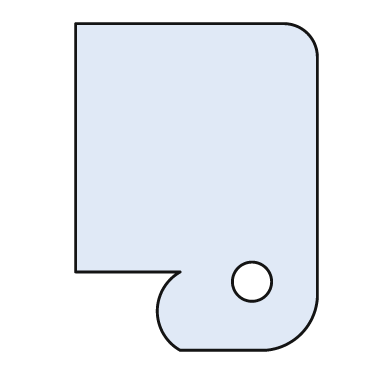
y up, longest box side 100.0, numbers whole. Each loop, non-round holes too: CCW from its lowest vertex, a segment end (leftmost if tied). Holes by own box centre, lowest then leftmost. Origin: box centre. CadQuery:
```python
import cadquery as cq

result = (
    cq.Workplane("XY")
    .moveTo(-5.0, -50.0)
    .lineTo(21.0, -50.0)
    .threePointArc((32.0, -45.0), (37.0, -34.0))
    .lineTo(37.0, 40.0)
    .threePointArc((34.0, 47.0), (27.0, 50.0))
    .lineTo(-37.0, 50.0)
    .lineTo(-37.0, -26.0)
    .lineTo(-5.0, -26.0)
    .threePointArc((-12.0, -38.0), (-5.0, -50.0))
    .close()
    .moveTo(17.0, -29.0)
    .circle(6.0)
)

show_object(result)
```